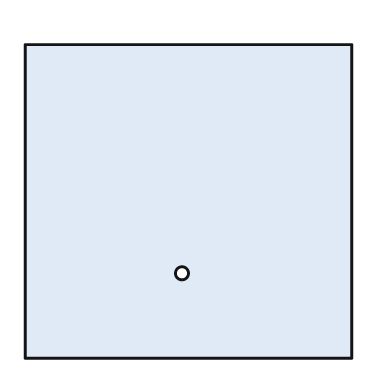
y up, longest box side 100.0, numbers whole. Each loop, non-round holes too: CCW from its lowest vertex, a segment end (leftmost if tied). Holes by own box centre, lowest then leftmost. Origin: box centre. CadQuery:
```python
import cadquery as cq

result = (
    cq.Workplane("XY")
    .moveTo(-50.0, -48.0)
    .lineTo(50.0, -48.0)
    .lineTo(50.0, 48.0)
    .lineTo(-50.0, 48.0)
    .close()
    .moveTo(-2.0, -22.0)
    .circle(2.0)
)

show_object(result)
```